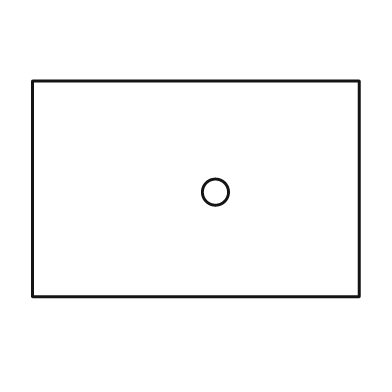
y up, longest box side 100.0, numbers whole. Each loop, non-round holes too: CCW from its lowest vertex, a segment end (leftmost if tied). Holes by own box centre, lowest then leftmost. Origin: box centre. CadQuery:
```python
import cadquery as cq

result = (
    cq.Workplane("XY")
    .moveTo(-50.0, -33.0)
    .lineTo(50.0, -33.0)
    .lineTo(50.0, 33.0)
    .lineTo(-50.0, 33.0)
    .close()
    .moveTo(6.0, -1.0)
    .circle(4.0)
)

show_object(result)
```